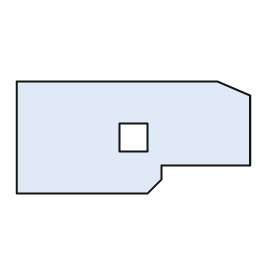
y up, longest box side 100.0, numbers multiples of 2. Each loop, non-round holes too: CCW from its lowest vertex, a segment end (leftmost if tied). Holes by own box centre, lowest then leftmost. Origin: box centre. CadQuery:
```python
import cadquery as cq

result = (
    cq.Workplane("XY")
    .moveTo(-50.0, -24.0)
    .lineTo(6.0, -24.0)
    .lineTo(12.0, -18.0)
    .lineTo(12.0, -12.0)
    .lineTo(50.0, -12.0)
    .lineTo(50.0, 18.0)
    .lineTo(36.0, 24.0)
    .lineTo(-50.0, 24.0)
    .close()
    .moveTo(-6.0, -6.0)
    .lineTo(6.0, -6.0)
    .lineTo(6.0, 6.0)
    .lineTo(-6.0, 6.0)
    .close()
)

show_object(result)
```